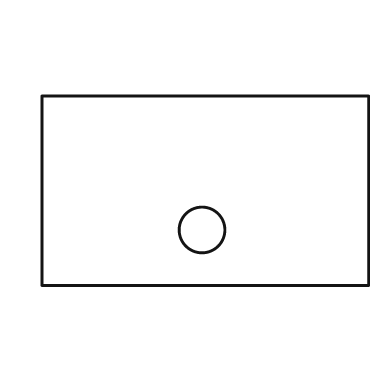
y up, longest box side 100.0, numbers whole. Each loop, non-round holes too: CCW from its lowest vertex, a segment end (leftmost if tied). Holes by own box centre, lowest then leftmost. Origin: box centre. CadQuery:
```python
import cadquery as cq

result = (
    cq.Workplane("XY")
    .moveTo(-50.0, -29.0)
    .lineTo(50.0, -29.0)
    .lineTo(50.0, 29.0)
    .lineTo(-50.0, 29.0)
    .close()
    .moveTo(-1.0, -12.0)
    .circle(7.0)
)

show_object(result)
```